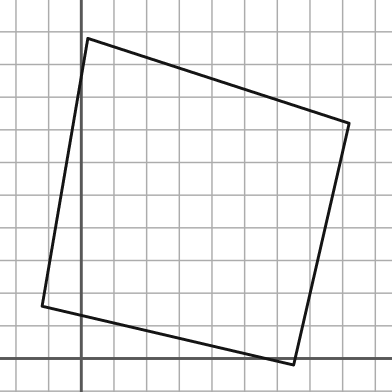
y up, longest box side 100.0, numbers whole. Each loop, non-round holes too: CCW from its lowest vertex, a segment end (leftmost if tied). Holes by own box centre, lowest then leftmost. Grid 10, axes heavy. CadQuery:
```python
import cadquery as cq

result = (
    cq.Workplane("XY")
    .moveTo(65.0, -2.0)
    .lineTo(82.0, 72.0)
    .lineTo(2.0, 98.0)
    .lineTo(-12.0, 16.0)
    .close()
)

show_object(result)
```